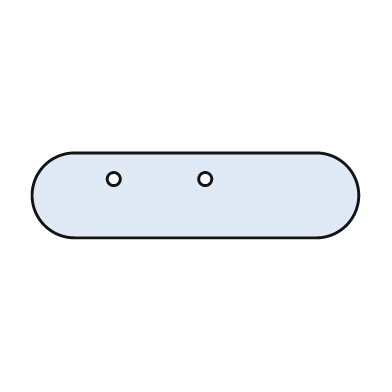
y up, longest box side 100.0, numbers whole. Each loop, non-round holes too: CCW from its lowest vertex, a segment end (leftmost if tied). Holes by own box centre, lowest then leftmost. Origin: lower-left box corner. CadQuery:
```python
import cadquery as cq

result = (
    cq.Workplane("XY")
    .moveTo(13.0, 0.0)
    .lineTo(87.0, 0.0)
    .threePointArc((100.0, 13.0), (87.0, 26.0))
    .lineTo(13.0, 26.0)
    .threePointArc((0.0, 13.0), (13.0, 0.0))
    .close()
    .moveTo(25.0, 18.0)
    .circle(2.0)
    .moveTo(53.0, 18.0)
    .circle(2.0)
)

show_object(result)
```